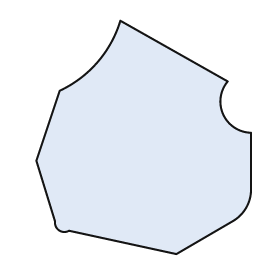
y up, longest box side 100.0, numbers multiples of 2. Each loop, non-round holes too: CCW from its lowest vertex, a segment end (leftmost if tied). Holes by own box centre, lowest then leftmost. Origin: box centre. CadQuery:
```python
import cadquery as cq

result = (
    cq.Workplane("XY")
    .moveTo(14.0, -50.0)
    .lineTo(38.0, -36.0)
    .threePointArc((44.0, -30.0), (46.0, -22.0))
    .lineTo(46.0, 2.0)
    .threePointArc((34.0, 10.0), (36.0, 24.0))
    .lineTo(-10.0, 50.0)
    .threePointArc((-20.0, 32.0), (-36.0, 20.0))
    .lineTo(-46.0, -10.0)
    .lineTo(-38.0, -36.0)
    .threePointArc((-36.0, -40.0), (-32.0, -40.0))
    .close()
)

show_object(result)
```